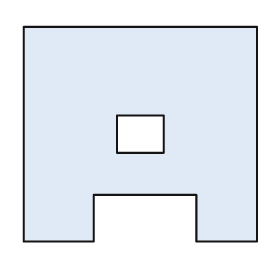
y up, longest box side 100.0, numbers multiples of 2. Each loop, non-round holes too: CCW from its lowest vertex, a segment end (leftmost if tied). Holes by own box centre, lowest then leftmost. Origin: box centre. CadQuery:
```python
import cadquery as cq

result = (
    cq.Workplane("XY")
    .moveTo(-50.0, -46.0)
    .lineTo(-20.0, -46.0)
    .lineTo(-20.0, -26.0)
    .lineTo(24.0, -26.0)
    .lineTo(24.0, -46.0)
    .lineTo(50.0, -46.0)
    .lineTo(50.0, 46.0)
    .lineTo(-50.0, 46.0)
    .close()
    .moveTo(-10.0, -8.0)
    .lineTo(10.0, -8.0)
    .lineTo(10.0, 8.0)
    .lineTo(-10.0, 8.0)
    .close()
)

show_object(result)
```